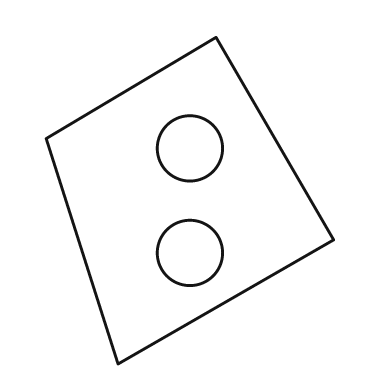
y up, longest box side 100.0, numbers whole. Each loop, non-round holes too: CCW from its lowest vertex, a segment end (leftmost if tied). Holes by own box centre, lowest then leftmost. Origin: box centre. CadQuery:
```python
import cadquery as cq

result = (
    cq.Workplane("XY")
    .moveTo(-22.0, -50.0)
    .lineTo(44.0, -12.0)
    .lineTo(8.0, 50.0)
    .lineTo(-44.0, 19.0)
    .close()
    .moveTo(0.0, -16.0)
    .circle(10.0)
    .moveTo(0.0, 16.0)
    .circle(10.0)
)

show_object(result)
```